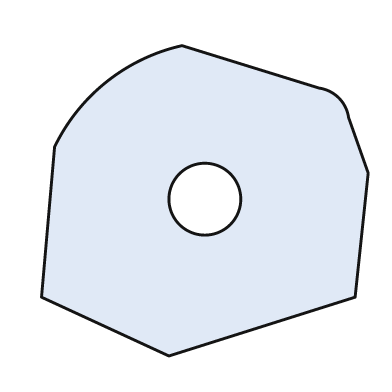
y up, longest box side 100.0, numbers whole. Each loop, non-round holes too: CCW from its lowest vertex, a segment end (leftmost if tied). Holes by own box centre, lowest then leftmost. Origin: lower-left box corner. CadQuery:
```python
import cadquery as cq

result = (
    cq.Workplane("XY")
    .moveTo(39.0, 0.0)
    .lineTo(96.0, 18.0)
    .lineTo(100.0, 56.0)
    .lineTo(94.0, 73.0)
    .threePointArc((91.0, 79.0), (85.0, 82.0))
    .lineTo(43.0, 95.0)
    .threePointArc((20.0, 84.0), (4.0, 64.0))
    .lineTo(0.0, 18.0)
    .close()
    .moveTo(50.0, 48.0)
    .circle(11.0)
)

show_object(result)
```